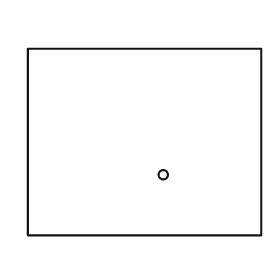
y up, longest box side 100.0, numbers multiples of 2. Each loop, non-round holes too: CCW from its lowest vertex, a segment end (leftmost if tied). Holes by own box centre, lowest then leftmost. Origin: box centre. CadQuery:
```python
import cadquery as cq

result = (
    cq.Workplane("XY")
    .moveTo(-50.0, -40.0)
    .lineTo(50.0, -40.0)
    .lineTo(50.0, 40.0)
    .lineTo(-50.0, 40.0)
    .close()
    .moveTo(8.0, -14.0)
    .circle(2.0)
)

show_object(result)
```